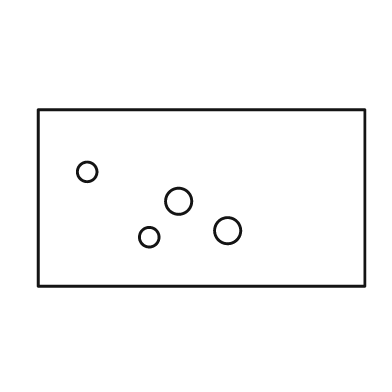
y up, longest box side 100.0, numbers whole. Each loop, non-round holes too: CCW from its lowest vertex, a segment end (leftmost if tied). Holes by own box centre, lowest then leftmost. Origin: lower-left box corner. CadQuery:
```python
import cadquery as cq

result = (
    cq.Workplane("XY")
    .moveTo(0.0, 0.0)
    .lineTo(100.0, 0.0)
    .lineTo(100.0, 54.0)
    .lineTo(0.0, 54.0)
    .close()
    .moveTo(34.0, 15.0)
    .circle(3.0)
    .moveTo(58.0, 17.0)
    .circle(4.0)
    .moveTo(43.0, 26.0)
    .circle(4.0)
    .moveTo(15.0, 35.0)
    .circle(3.0)
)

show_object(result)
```